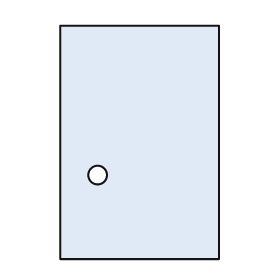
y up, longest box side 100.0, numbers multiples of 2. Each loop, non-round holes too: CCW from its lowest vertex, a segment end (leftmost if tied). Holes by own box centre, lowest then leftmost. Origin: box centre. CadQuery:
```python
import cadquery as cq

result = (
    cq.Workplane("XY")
    .moveTo(-34.0, -50.0)
    .lineTo(34.0, -50.0)
    .lineTo(34.0, 50.0)
    .lineTo(-34.0, 50.0)
    .close()
    .moveTo(-18.0, -14.0)
    .circle(4.0)
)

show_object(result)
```